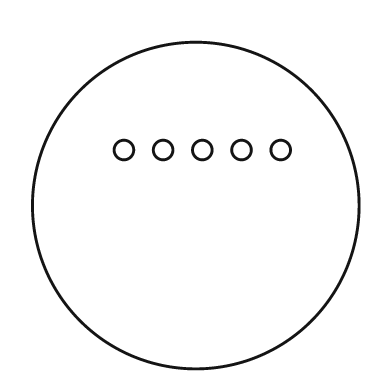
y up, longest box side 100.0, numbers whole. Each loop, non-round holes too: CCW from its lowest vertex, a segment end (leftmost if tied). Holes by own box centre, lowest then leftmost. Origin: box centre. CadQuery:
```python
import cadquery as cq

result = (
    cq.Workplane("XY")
    .moveTo(0.0, 0.0)
    .circle(50.0)
    .moveTo(-22.0, 17.0)
    .circle(3.0)
    .moveTo(-10.0, 17.0)
    .circle(3.0)
    .moveTo(2.0, 17.0)
    .circle(3.0)
    .moveTo(14.0, 17.0)
    .circle(3.0)
    .moveTo(26.0, 17.0)
    .circle(3.0)
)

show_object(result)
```